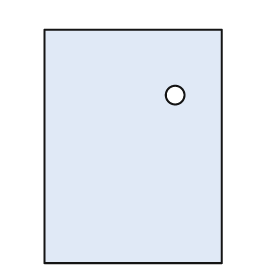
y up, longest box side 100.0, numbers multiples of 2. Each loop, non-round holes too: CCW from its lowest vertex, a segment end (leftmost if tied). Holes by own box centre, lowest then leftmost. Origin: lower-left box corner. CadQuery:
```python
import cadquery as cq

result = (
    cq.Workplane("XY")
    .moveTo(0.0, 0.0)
    .lineTo(76.0, 0.0)
    .lineTo(76.0, 100.0)
    .lineTo(0.0, 100.0)
    .close()
    .moveTo(56.0, 72.0)
    .circle(4.0)
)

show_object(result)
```